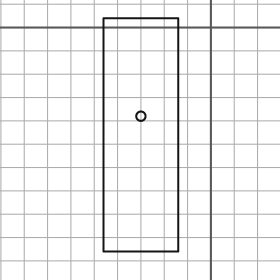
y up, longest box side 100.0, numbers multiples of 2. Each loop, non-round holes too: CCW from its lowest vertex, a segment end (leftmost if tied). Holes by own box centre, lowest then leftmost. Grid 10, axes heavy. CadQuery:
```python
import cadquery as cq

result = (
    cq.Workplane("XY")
    .moveTo(-46.0, -96.0)
    .lineTo(-14.0, -96.0)
    .lineTo(-14.0, 4.0)
    .lineTo(-46.0, 4.0)
    .close()
    .moveTo(-30.0, -38.0)
    .circle(2.0)
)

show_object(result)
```